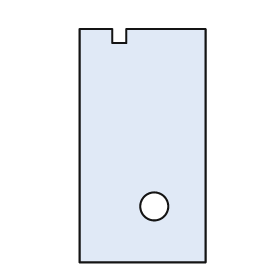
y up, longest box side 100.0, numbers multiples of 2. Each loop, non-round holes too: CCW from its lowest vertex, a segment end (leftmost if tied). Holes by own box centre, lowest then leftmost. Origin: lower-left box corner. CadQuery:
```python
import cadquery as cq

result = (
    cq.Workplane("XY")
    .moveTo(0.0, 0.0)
    .lineTo(54.0, 0.0)
    .lineTo(54.0, 100.0)
    .lineTo(20.0, 100.0)
    .lineTo(20.0, 94.0)
    .lineTo(14.0, 94.0)
    .lineTo(14.0, 100.0)
    .lineTo(0.0, 100.0)
    .close()
    .moveTo(32.0, 24.0)
    .circle(6.0)
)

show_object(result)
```